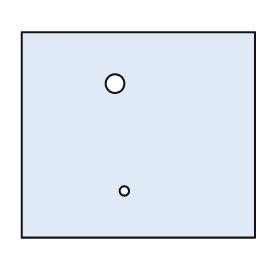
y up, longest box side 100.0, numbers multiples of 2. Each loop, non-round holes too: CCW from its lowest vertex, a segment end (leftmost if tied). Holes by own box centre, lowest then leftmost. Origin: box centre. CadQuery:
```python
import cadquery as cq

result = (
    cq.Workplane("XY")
    .moveTo(-50.0, -44.0)
    .lineTo(50.0, -44.0)
    .lineTo(50.0, 44.0)
    .lineTo(-50.0, 44.0)
    .close()
    .moveTo(-6.0, -24.0)
    .circle(2.0)
    .moveTo(-10.0, 22.0)
    .circle(4.0)
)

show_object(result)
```